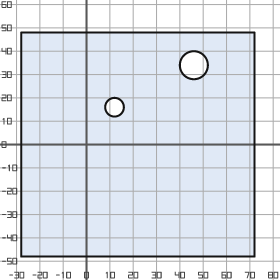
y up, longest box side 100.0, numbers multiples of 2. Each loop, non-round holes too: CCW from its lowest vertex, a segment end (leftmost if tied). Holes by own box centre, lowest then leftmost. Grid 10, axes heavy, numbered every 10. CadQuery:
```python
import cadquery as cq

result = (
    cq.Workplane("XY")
    .moveTo(-28.0, -48.0)
    .lineTo(72.0, -48.0)
    .lineTo(72.0, 48.0)
    .lineTo(-28.0, 48.0)
    .close()
    .moveTo(12.0, 16.0)
    .circle(4.0)
    .moveTo(46.0, 34.0)
    .circle(6.0)
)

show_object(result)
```